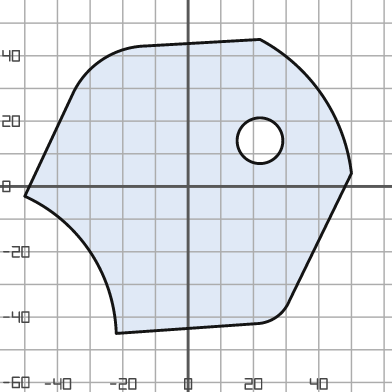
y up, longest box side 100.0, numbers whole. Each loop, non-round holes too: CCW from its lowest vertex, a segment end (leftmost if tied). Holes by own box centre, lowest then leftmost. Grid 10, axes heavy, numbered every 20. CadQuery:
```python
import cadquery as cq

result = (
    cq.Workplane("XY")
    .moveTo(-22.0, -45.0)
    .lineTo(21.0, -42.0)
    .threePointArc((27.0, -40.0), (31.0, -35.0))
    .lineTo(50.0, 4.0)
    .threePointArc((41.0, 28.0), (22.0, 45.0))
    .lineTo(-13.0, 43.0)
    .threePointArc((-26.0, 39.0), (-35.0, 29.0))
    .lineTo(-50.0, -3.0)
    .threePointArc((-30.0, -20.0), (-22.0, -45.0))
    .close()
    .moveTo(22.0, 14.0)
    .circle(7.0)
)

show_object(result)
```